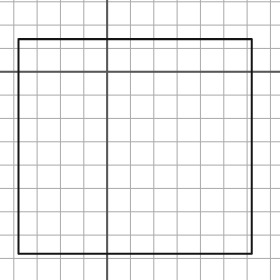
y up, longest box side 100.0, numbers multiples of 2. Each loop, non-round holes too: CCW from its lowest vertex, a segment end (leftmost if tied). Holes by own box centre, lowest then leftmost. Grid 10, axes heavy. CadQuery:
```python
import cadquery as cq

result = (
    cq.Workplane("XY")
    .moveTo(-38.0, -78.0)
    .lineTo(62.0, -78.0)
    .lineTo(62.0, 14.0)
    .lineTo(-38.0, 14.0)
    .close()
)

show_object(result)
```